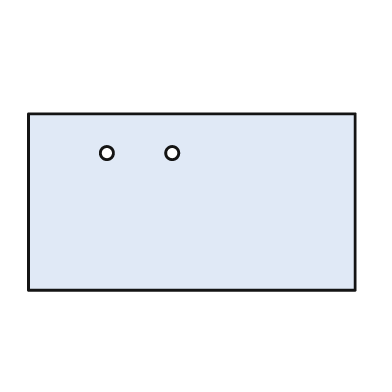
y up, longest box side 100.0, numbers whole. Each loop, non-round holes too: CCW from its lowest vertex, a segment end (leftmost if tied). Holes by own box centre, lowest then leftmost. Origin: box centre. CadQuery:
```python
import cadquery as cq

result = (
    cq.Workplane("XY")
    .moveTo(-50.0, -27.0)
    .lineTo(50.0, -27.0)
    .lineTo(50.0, 27.0)
    .lineTo(-50.0, 27.0)
    .close()
    .moveTo(-26.0, 15.0)
    .circle(2.0)
    .moveTo(-6.0, 15.0)
    .circle(2.0)
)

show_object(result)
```